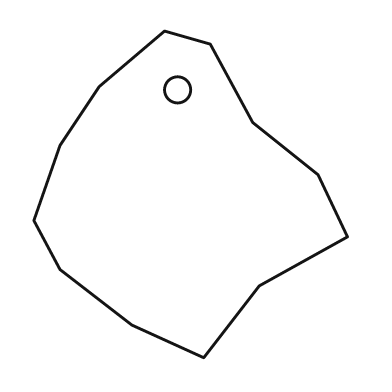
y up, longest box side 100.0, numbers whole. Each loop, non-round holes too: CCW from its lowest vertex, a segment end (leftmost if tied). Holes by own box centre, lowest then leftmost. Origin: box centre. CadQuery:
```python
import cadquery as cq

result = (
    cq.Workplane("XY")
    .moveTo(4.0, -50.0)
    .lineTo(21.0, -28.0)
    .lineTo(48.0, -13.0)
    .lineTo(39.0, 6.0)
    .lineTo(19.0, 22.0)
    .lineTo(6.0, 46.0)
    .lineTo(-8.0, 50.0)
    .lineTo(-28.0, 33.0)
    .lineTo(-40.0, 15.0)
    .lineTo(-48.0, -8.0)
    .lineTo(-40.0, -23.0)
    .lineTo(-18.0, -40.0)
    .close()
    .moveTo(-4.0, 32.0)
    .circle(4.0)
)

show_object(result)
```